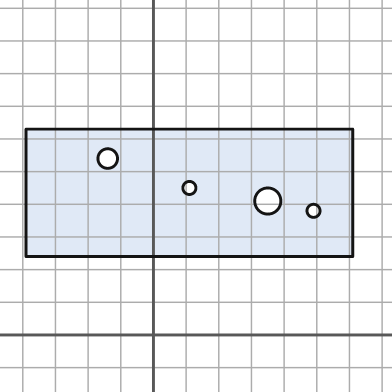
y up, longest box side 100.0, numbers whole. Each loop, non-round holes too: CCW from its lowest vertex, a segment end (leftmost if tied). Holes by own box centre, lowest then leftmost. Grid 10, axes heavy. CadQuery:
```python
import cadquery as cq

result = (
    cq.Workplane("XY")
    .moveTo(-39.0, 24.0)
    .lineTo(61.0, 24.0)
    .lineTo(61.0, 63.0)
    .lineTo(-39.0, 63.0)
    .close()
    .moveTo(49.0, 38.0)
    .circle(2.0)
    .moveTo(35.0, 41.0)
    .circle(4.0)
    .moveTo(11.0, 45.0)
    .circle(2.0)
    .moveTo(-14.0, 54.0)
    .circle(3.0)
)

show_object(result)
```